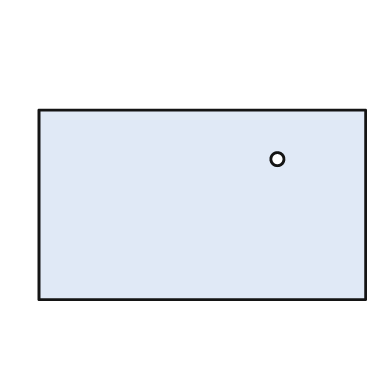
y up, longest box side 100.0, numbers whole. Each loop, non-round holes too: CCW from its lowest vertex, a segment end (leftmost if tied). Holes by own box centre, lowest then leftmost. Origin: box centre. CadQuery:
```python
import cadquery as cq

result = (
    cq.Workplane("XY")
    .moveTo(-50.0, -29.0)
    .lineTo(50.0, -29.0)
    .lineTo(50.0, 29.0)
    .lineTo(-50.0, 29.0)
    .close()
    .moveTo(23.0, 14.0)
    .circle(2.0)
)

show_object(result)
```